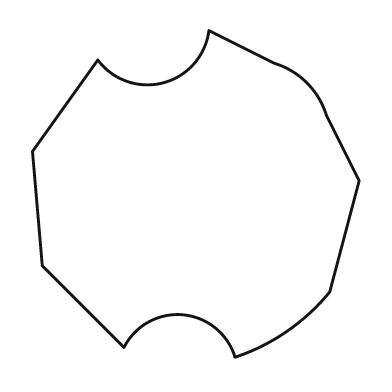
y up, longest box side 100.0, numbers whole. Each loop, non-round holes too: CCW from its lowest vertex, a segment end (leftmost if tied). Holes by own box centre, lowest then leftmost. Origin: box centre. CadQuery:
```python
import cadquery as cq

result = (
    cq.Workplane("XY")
    .moveTo(12.0, -50.0)
    .threePointArc((28.0, -42.0), (41.0, -30.0))
    .lineTo(50.0, 4.0)
    .lineTo(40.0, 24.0)
    .threePointArc((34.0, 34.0), (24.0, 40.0))
    .lineTo(4.0, 50.0)
    .threePointArc((-10.0, 34.0), (-30.0, 41.0))
    .lineTo(-50.0, 13.0)
    .lineTo(-47.0, -22.0)
    .lineTo(-22.0, -47.0)
    .threePointArc((-4.0, -37.0), (12.0, -50.0))
    .close()
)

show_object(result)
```